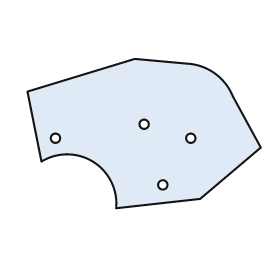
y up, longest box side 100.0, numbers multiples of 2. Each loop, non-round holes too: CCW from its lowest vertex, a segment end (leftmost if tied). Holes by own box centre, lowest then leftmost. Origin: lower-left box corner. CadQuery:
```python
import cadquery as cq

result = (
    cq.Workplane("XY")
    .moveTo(38.0, 0.0)
    .lineTo(74.0, 4.0)
    .lineTo(100.0, 26.0)
    .lineTo(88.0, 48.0)
    .threePointArc((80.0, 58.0), (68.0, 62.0))
    .lineTo(46.0, 64.0)
    .lineTo(0.0, 50.0)
    .lineTo(6.0, 20.0)
    .threePointArc((28.0, 20.0), (38.0, 0.0))
    .close()
    .moveTo(58.0, 10.0)
    .circle(2.0)
    .moveTo(12.0, 30.0)
    .circle(2.0)
    .moveTo(70.0, 30.0)
    .circle(2.0)
    .moveTo(50.0, 36.0)
    .circle(2.0)
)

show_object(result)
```